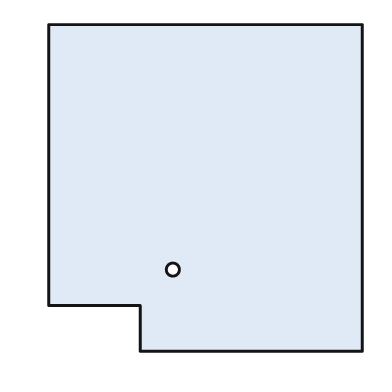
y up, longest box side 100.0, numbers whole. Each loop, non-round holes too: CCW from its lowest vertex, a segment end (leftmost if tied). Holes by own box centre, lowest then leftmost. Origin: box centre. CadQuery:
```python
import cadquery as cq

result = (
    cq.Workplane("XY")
    .moveTo(-20.0, -50.0)
    .lineTo(48.0, -50.0)
    .lineTo(48.0, 50.0)
    .lineTo(-48.0, 50.0)
    .lineTo(-48.0, -36.0)
    .lineTo(-20.0, -36.0)
    .close()
    .moveTo(-10.0, -25.0)
    .circle(2.0)
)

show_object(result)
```